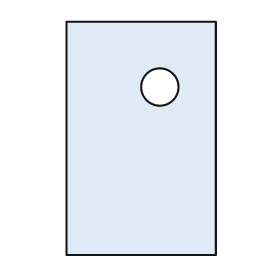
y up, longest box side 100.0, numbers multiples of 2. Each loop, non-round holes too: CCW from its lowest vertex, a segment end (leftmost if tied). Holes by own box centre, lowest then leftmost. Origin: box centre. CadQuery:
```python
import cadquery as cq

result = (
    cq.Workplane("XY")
    .moveTo(-32.0, -50.0)
    .lineTo(32.0, -50.0)
    .lineTo(32.0, 50.0)
    .lineTo(-32.0, 50.0)
    .close()
    .moveTo(8.0, 22.0)
    .circle(8.0)
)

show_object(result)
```